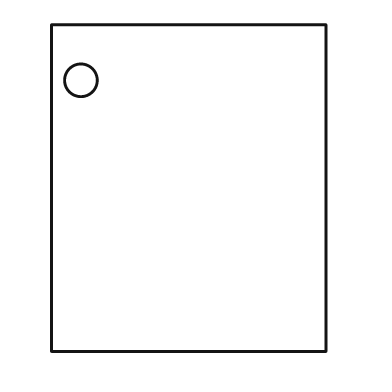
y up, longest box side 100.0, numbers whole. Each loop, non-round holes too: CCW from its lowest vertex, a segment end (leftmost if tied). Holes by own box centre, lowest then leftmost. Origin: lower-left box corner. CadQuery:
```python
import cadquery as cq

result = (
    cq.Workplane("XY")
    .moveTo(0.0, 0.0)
    .lineTo(84.0, 0.0)
    .lineTo(84.0, 100.0)
    .lineTo(0.0, 100.0)
    .close()
    .moveTo(9.0, 83.0)
    .circle(5.0)
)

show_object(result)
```